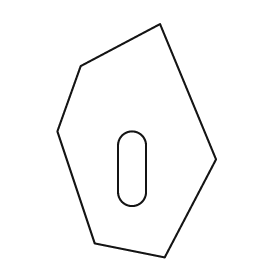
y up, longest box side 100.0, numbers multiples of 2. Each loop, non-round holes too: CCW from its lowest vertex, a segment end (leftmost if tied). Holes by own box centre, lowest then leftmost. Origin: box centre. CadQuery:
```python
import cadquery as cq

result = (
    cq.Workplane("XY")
    .moveTo(12.0, -50.0)
    .lineTo(34.0, -8.0)
    .lineTo(10.0, 50.0)
    .lineTo(-24.0, 32.0)
    .lineTo(-34.0, 4.0)
    .lineTo(-18.0, -44.0)
    .close()
    .moveTo(-8.0, -22.0)
    .threePointArc((-2.0, -28.0), (4.0, -22.0))
    .lineTo(4.0, -2.0)
    .threePointArc((-2.0, 4.0), (-8.0, -2.0))
    .close()
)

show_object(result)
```